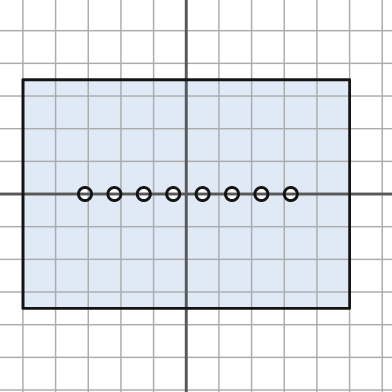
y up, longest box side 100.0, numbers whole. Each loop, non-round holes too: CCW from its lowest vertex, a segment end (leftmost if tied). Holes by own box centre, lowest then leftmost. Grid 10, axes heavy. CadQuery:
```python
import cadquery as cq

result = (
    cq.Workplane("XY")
    .moveTo(-50.0, -35.0)
    .lineTo(50.0, -35.0)
    .lineTo(50.0, 35.0)
    .lineTo(-50.0, 35.0)
    .close()
    .moveTo(-31.0, 0.0)
    .circle(2.0)
    .moveTo(-22.0, 0.0)
    .circle(2.0)
    .moveTo(-13.0, 0.0)
    .circle(2.0)
    .moveTo(-4.0, 0.0)
    .circle(2.0)
    .moveTo(5.0, 0.0)
    .circle(2.0)
    .moveTo(14.0, 0.0)
    .circle(2.0)
    .moveTo(23.0, 0.0)
    .circle(2.0)
    .moveTo(32.0, 0.0)
    .circle(2.0)
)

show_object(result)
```